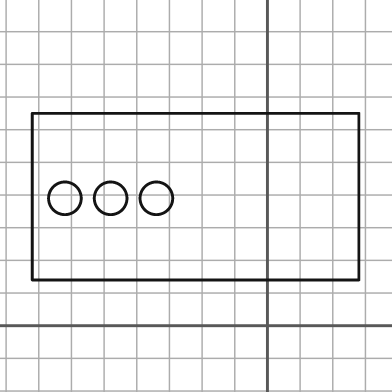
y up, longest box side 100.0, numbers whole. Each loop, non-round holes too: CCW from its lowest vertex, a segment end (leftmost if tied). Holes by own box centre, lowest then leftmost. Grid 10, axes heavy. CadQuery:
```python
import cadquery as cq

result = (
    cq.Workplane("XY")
    .moveTo(-72.0, 14.0)
    .lineTo(28.0, 14.0)
    .lineTo(28.0, 65.0)
    .lineTo(-72.0, 65.0)
    .close()
    .moveTo(-62.0, 39.0)
    .circle(5.0)
    .moveTo(-48.0, 39.0)
    .circle(5.0)
    .moveTo(-34.0, 39.0)
    .circle(5.0)
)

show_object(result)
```